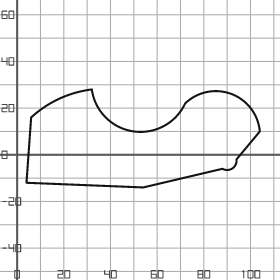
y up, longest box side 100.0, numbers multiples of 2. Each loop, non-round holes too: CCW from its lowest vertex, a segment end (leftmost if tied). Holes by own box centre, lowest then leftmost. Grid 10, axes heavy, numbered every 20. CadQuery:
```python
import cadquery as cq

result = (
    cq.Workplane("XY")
    .moveTo(54.0, -14.0)
    .lineTo(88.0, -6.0)
    .threePointArc((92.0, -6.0), (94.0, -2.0))
    .lineTo(104.0, 10.0)
    .threePointArc((92.0, 26.0), (72.0, 22.0))
    .threePointArc((50.0, 10.0), (32.0, 28.0))
    .threePointArc((18.0, 24.0), (6.0, 16.0))
    .lineTo(4.0, -12.0)
    .close()
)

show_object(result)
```